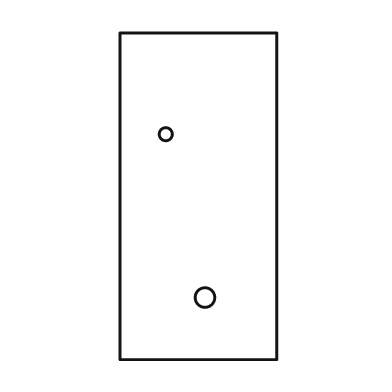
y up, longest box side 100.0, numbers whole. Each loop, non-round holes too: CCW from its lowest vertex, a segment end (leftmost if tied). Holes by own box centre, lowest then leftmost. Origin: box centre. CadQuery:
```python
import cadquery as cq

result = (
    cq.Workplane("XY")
    .moveTo(-24.0, -50.0)
    .lineTo(24.0, -50.0)
    .lineTo(24.0, 50.0)
    .lineTo(-24.0, 50.0)
    .close()
    .moveTo(2.0, -31.0)
    .circle(3.0)
    .moveTo(-10.0, 19.0)
    .circle(2.0)
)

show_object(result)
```